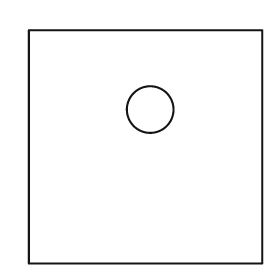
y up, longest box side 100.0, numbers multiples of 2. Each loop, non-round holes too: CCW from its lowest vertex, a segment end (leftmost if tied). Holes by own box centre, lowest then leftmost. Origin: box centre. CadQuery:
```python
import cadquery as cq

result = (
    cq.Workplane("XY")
    .moveTo(-50.0, -50.0)
    .lineTo(50.0, -50.0)
    .lineTo(50.0, 50.0)
    .lineTo(-50.0, 50.0)
    .close()
    .moveTo(2.0, 16.0)
    .circle(10.0)
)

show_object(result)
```